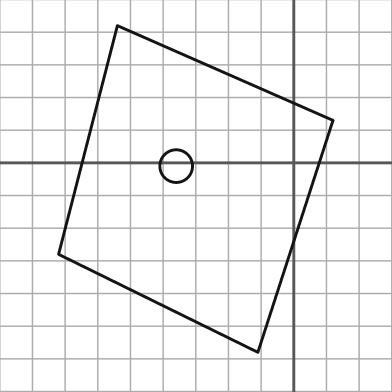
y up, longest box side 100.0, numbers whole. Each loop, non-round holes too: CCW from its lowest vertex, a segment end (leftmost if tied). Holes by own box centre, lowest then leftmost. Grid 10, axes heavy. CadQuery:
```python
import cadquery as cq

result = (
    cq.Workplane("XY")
    .moveTo(-11.0, -58.0)
    .lineTo(12.0, 13.0)
    .lineTo(-54.0, 42.0)
    .lineTo(-72.0, -28.0)
    .close()
    .moveTo(-36.0, -1.0)
    .circle(5.0)
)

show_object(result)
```